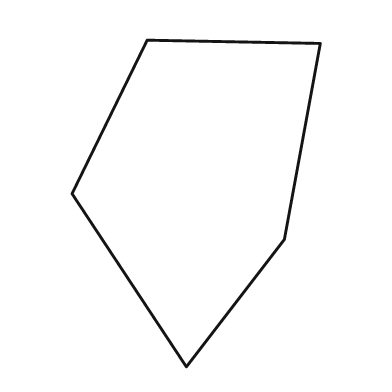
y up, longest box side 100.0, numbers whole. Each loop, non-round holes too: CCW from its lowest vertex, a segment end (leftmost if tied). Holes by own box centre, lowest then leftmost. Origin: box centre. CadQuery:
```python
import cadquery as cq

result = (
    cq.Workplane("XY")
    .moveTo(-3.0, -50.0)
    .lineTo(27.0, -11.0)
    .lineTo(38.0, 49.0)
    .lineTo(-15.0, 50.0)
    .lineTo(-38.0, 3.0)
    .close()
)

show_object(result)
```